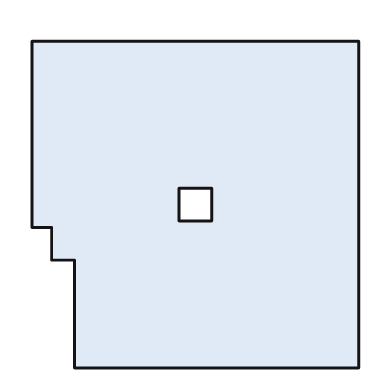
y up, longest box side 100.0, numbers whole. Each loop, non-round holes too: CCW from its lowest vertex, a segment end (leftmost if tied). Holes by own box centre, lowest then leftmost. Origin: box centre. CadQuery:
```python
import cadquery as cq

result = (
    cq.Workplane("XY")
    .moveTo(-37.0, -50.0)
    .lineTo(50.0, -50.0)
    .lineTo(50.0, 50.0)
    .lineTo(-50.0, 50.0)
    .lineTo(-50.0, -7.0)
    .lineTo(-44.0, -7.0)
    .lineTo(-44.0, -17.0)
    .lineTo(-37.0, -17.0)
    .close()
    .moveTo(-5.0, -5.0)
    .lineTo(5.0, -5.0)
    .lineTo(5.0, 5.0)
    .lineTo(-5.0, 5.0)
    .close()
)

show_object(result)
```